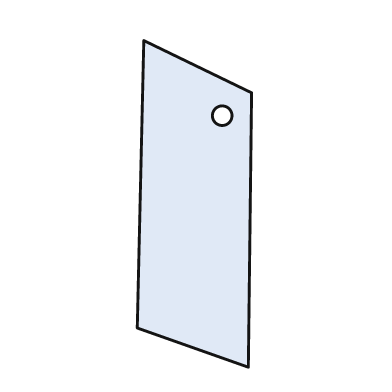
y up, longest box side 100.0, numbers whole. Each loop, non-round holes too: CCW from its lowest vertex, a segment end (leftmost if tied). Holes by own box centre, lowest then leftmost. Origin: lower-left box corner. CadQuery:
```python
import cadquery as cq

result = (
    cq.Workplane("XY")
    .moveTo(34.0, 0.0)
    .lineTo(35.0, 84.0)
    .lineTo(2.0, 100.0)
    .lineTo(0.0, 12.0)
    .close()
    .moveTo(26.0, 77.0)
    .circle(3.0)
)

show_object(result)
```